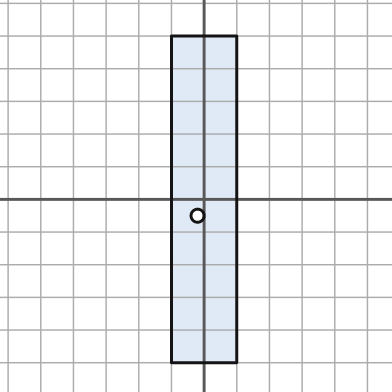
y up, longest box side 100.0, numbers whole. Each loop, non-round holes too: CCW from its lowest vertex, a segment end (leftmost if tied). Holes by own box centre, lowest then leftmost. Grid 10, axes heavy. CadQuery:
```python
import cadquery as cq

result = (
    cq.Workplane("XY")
    .moveTo(-10.0, -50.0)
    .lineTo(10.0, -50.0)
    .lineTo(10.0, 50.0)
    .lineTo(-10.0, 50.0)
    .close()
    .moveTo(-2.0, -5.0)
    .circle(2.0)
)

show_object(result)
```